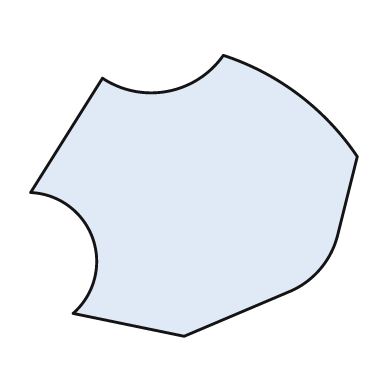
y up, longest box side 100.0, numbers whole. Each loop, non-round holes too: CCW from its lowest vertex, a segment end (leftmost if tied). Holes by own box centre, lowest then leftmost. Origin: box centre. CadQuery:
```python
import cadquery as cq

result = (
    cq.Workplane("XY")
    .moveTo(-3.0, -43.0)
    .lineTo(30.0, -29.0)
    .threePointArc((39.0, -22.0), (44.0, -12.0))
    .lineTo(50.0, 12.0)
    .threePointArc((32.0, 31.0), (9.0, 43.0))
    .threePointArc((-8.0, 32.0), (-28.0, 36.0))
    .lineTo(-50.0, 1.0)
    .threePointArc((-31.0, -13.0), (-37.0, -36.0))
    .close()
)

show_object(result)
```